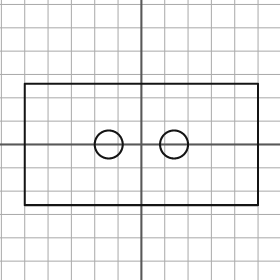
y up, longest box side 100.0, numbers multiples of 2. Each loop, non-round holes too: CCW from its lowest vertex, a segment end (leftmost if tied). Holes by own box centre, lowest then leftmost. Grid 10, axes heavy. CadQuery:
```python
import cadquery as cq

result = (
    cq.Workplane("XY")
    .moveTo(-50.0, -26.0)
    .lineTo(50.0, -26.0)
    .lineTo(50.0, 26.0)
    .lineTo(-50.0, 26.0)
    .close()
    .moveTo(-14.0, 0.0)
    .circle(6.0)
    .moveTo(14.0, 0.0)
    .circle(6.0)
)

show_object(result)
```